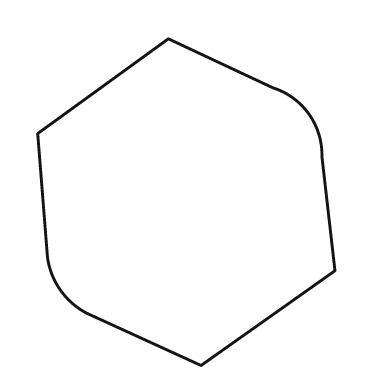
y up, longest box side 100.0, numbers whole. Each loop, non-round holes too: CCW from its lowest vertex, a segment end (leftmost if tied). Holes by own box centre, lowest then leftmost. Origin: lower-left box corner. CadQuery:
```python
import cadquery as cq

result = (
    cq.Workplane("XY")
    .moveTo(50.0, 0.0)
    .lineTo(91.0, 29.0)
    .lineTo(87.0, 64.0)
    .threePointArc((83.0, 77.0), (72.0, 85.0))
    .lineTo(40.0, 100.0)
    .lineTo(0.0, 71.0)
    .lineTo(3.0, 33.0)
    .threePointArc((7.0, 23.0), (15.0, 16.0))
    .close()
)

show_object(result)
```